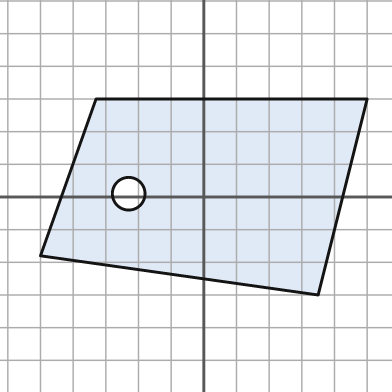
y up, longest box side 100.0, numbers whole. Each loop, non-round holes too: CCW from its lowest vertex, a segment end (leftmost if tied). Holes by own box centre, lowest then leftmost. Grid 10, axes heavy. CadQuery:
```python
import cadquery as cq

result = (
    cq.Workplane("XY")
    .moveTo(35.0, -30.0)
    .lineTo(50.0, 30.0)
    .lineTo(-33.0, 30.0)
    .lineTo(-50.0, -18.0)
    .close()
    .moveTo(-23.0, 1.0)
    .circle(5.0)
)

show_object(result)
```